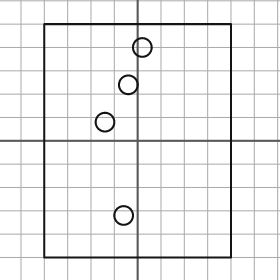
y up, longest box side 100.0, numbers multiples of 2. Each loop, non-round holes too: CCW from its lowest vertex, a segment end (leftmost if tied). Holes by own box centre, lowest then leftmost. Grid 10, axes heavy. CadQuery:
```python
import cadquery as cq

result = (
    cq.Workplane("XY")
    .moveTo(-40.0, -50.0)
    .lineTo(40.0, -50.0)
    .lineTo(40.0, 50.0)
    .lineTo(-40.0, 50.0)
    .close()
    .moveTo(-6.0, -32.0)
    .circle(4.0)
    .moveTo(-14.0, 8.0)
    .circle(4.0)
    .moveTo(-4.0, 24.0)
    .circle(4.0)
    .moveTo(2.0, 40.0)
    .circle(4.0)
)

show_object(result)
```